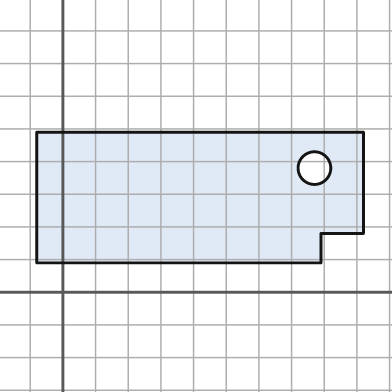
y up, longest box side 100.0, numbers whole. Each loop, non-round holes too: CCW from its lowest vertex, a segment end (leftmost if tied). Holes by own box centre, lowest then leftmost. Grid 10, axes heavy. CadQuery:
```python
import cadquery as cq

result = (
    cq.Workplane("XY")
    .moveTo(-8.0, 9.0)
    .lineTo(79.0, 9.0)
    .lineTo(79.0, 18.0)
    .lineTo(92.0, 18.0)
    .lineTo(92.0, 49.0)
    .lineTo(-8.0, 49.0)
    .close()
    .moveTo(77.0, 38.0)
    .circle(5.0)
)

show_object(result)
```